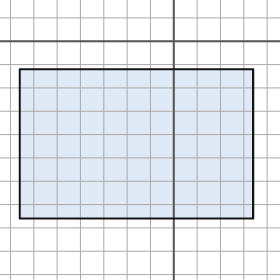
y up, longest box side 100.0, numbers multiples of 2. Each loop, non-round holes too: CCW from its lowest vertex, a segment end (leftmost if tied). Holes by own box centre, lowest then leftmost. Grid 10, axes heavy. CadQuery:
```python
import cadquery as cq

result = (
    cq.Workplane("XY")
    .moveTo(-66.0, -76.0)
    .lineTo(34.0, -76.0)
    .lineTo(34.0, -12.0)
    .lineTo(-66.0, -12.0)
    .close()
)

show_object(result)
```